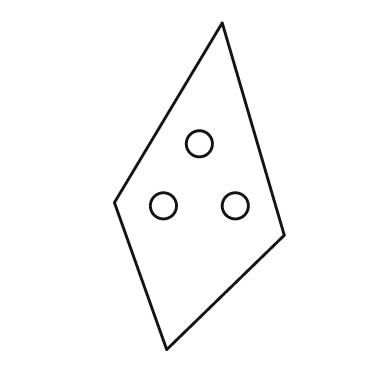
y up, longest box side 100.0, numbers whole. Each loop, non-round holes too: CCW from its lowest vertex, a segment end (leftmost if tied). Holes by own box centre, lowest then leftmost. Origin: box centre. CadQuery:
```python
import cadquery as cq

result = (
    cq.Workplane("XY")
    .moveTo(-10.0, -50.0)
    .lineTo(26.0, -15.0)
    .lineTo(7.0, 50.0)
    .lineTo(-26.0, -5.0)
    .close()
    .moveTo(-11.0, -6.0)
    .circle(4.0)
    .moveTo(11.0, -6.0)
    .circle(4.0)
    .moveTo(0.0, 13.0)
    .circle(4.0)
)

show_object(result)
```